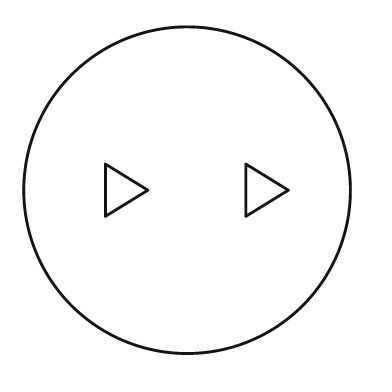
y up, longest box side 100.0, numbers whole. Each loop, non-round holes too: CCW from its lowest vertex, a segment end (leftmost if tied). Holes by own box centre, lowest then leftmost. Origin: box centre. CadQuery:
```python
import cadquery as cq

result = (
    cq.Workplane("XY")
    .moveTo(0.0, 0.0)
    .circle(50.0)
    .moveTo(-25.0, -8.0)
    .lineTo(-12.0, 0.0)
    .lineTo(-25.0, 8.0)
    .close()
    .moveTo(18.0, -8.0)
    .lineTo(31.0, 0.0)
    .lineTo(18.0, 8.0)
    .close()
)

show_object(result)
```